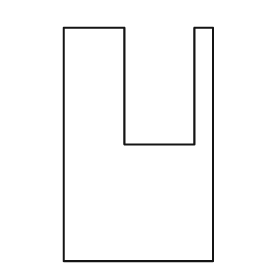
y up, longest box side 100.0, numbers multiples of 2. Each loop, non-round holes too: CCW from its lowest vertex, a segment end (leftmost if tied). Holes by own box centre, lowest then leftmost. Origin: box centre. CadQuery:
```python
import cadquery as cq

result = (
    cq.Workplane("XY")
    .moveTo(-32.0, -50.0)
    .lineTo(32.0, -50.0)
    .lineTo(32.0, 50.0)
    .lineTo(24.0, 50.0)
    .lineTo(24.0, 0.0)
    .lineTo(-6.0, 0.0)
    .lineTo(-6.0, 50.0)
    .lineTo(-32.0, 50.0)
    .close()
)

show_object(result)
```